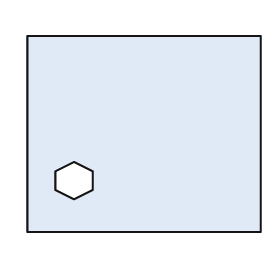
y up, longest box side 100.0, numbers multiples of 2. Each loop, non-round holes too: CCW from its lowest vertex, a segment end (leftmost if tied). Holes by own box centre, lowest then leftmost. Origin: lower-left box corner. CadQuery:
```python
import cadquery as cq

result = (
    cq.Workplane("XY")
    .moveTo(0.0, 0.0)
    .lineTo(100.0, 0.0)
    .lineTo(100.0, 84.0)
    .lineTo(0.0, 84.0)
    .close()
    .moveTo(20.0, 14.0)
    .lineTo(28.0, 18.0)
    .lineTo(28.0, 26.0)
    .lineTo(20.0, 30.0)
    .lineTo(12.0, 26.0)
    .lineTo(12.0, 18.0)
    .close()
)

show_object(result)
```